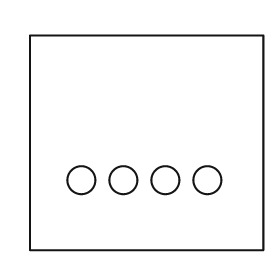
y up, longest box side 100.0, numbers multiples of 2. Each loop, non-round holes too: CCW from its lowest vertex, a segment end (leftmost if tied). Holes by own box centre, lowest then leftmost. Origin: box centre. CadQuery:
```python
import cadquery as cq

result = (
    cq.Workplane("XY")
    .moveTo(-50.0, -46.0)
    .lineTo(50.0, -46.0)
    .lineTo(50.0, 46.0)
    .lineTo(-50.0, 46.0)
    .close()
    .moveTo(-28.0, -16.0)
    .circle(6.0)
    .moveTo(-10.0, -16.0)
    .circle(6.0)
    .moveTo(8.0, -16.0)
    .circle(6.0)
    .moveTo(26.0, -16.0)
    .circle(6.0)
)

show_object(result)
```